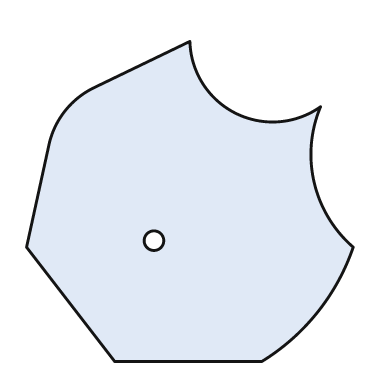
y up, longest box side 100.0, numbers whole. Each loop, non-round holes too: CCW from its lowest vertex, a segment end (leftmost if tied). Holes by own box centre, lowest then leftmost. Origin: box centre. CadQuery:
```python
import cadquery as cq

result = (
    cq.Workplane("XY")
    .moveTo(-23.0, -49.0)
    .lineTo(22.0, -49.0)
    .threePointArc((39.0, -34.0), (50.0, -14.0))
    .threePointArc((38.0, 6.0), (40.0, 29.0))
    .threePointArc((14.0, 27.0), (0.0, 49.0))
    .lineTo(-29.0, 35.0)
    .threePointArc((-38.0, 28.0), (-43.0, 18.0))
    .lineTo(-50.0, -14.0)
    .close()
    .moveTo(-11.0, -12.0)
    .circle(3.0)
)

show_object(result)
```